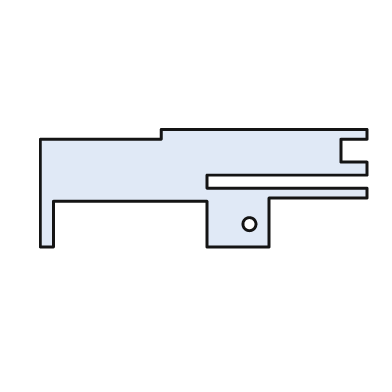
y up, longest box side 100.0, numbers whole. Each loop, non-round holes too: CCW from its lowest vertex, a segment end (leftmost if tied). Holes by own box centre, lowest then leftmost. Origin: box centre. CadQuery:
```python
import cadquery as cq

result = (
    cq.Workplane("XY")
    .moveTo(-50.0, -18.0)
    .lineTo(-46.0, -18.0)
    .lineTo(-46.0, -4.0)
    .lineTo(1.0, -4.0)
    .lineTo(1.0, -18.0)
    .lineTo(20.0, -18.0)
    .lineTo(20.0, -3.0)
    .lineTo(50.0, -3.0)
    .lineTo(50.0, 0.0)
    .lineTo(1.0, 0.0)
    .lineTo(1.0, 4.0)
    .lineTo(50.0, 4.0)
    .lineTo(50.0, 8.0)
    .lineTo(42.0, 8.0)
    .lineTo(42.0, 15.0)
    .lineTo(50.0, 15.0)
    .lineTo(50.0, 18.0)
    .lineTo(-13.0, 18.0)
    .lineTo(-13.0, 15.0)
    .lineTo(-50.0, 15.0)
    .close()
    .moveTo(14.0, -11.0)
    .circle(2.0)
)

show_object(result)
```